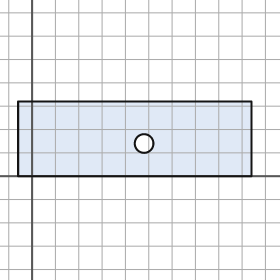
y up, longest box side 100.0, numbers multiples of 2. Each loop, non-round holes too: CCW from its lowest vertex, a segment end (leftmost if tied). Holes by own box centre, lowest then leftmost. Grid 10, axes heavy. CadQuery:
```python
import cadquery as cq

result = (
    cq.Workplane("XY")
    .moveTo(-6.0, 0.0)
    .lineTo(94.0, 0.0)
    .lineTo(94.0, 32.0)
    .lineTo(-6.0, 32.0)
    .close()
    .moveTo(48.0, 14.0)
    .circle(4.0)
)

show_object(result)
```